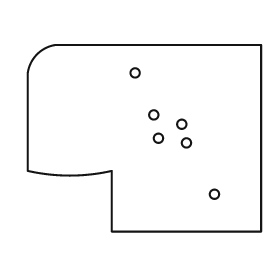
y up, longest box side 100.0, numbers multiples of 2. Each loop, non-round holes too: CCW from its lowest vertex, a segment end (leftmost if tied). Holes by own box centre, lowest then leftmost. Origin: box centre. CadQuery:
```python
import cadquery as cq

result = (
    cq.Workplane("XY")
    .moveTo(-14.0, -40.0)
    .lineTo(50.0, -40.0)
    .lineTo(50.0, 40.0)
    .lineTo(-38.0, 40.0)
    .threePointArc((-46.0, 36.0), (-50.0, 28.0))
    .lineTo(-50.0, -14.0)
    .threePointArc((-32.0, -16.0), (-14.0, -14.0))
    .close()
    .moveTo(30.0, -24.0)
    .circle(2.0)
    .moveTo(18.0, -2.0)
    .circle(2.0)
    .moveTo(6.0, 0.0)
    .circle(2.0)
    .moveTo(16.0, 6.0)
    .circle(2.0)
    .moveTo(4.0, 10.0)
    .circle(2.0)
    .moveTo(-4.0, 28.0)
    .circle(2.0)
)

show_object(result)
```